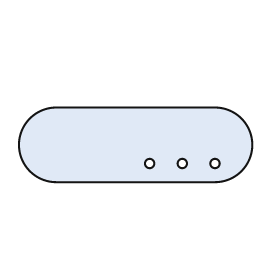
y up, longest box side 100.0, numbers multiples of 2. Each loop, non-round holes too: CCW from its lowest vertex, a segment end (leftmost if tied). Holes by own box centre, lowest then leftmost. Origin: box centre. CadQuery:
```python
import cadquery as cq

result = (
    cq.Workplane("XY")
    .moveTo(-34.0, -16.0)
    .lineTo(34.0, -16.0)
    .threePointArc((50.0, 0.0), (34.0, 16.0))
    .lineTo(-34.0, 16.0)
    .threePointArc((-50.0, 0.0), (-34.0, -16.0))
    .close()
    .moveTo(6.0, -8.0)
    .circle(2.0)
    .moveTo(20.0, -8.0)
    .circle(2.0)
    .moveTo(34.0, -8.0)
    .circle(2.0)
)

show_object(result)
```